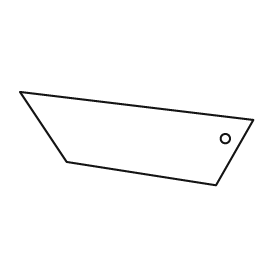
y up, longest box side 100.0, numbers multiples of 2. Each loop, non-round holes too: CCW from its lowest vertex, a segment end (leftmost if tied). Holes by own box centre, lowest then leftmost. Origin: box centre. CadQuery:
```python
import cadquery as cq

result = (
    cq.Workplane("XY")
    .moveTo(34.0, -20.0)
    .lineTo(50.0, 8.0)
    .lineTo(-50.0, 20.0)
    .lineTo(-30.0, -10.0)
    .close()
    .moveTo(38.0, 0.0)
    .circle(2.0)
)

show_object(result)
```